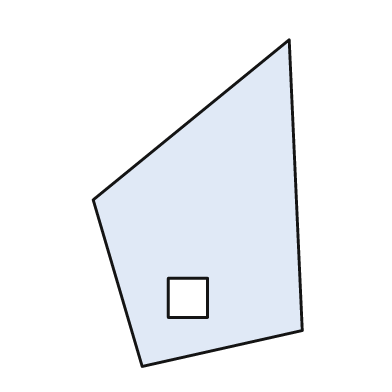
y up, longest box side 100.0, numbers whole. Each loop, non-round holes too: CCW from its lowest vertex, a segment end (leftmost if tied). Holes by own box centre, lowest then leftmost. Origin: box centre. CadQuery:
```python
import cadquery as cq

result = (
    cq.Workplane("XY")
    .moveTo(-17.0, -50.0)
    .lineTo(32.0, -39.0)
    .lineTo(28.0, 50.0)
    .lineTo(-32.0, 1.0)
    .close()
    .moveTo(-9.0, -35.0)
    .lineTo(3.0, -35.0)
    .lineTo(3.0, -23.0)
    .lineTo(-9.0, -23.0)
    .close()
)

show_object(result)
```